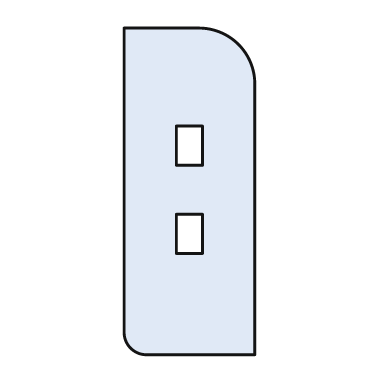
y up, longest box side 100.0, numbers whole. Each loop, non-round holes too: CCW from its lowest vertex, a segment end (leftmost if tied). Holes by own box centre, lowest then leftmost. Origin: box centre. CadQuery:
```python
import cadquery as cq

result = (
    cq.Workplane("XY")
    .moveTo(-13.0, -50.0)
    .lineTo(20.0, -50.0)
    .lineTo(20.0, 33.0)
    .threePointArc((15.0, 45.0), (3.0, 50.0))
    .lineTo(-20.0, 50.0)
    .lineTo(-20.0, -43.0)
    .threePointArc((-18.0, -48.0), (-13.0, -50.0))
    .close()
    .moveTo(-4.0, -19.0)
    .lineTo(4.0, -19.0)
    .lineTo(4.0, -7.0)
    .lineTo(-4.0, -7.0)
    .close()
    .moveTo(-4.0, 8.0)
    .lineTo(4.0, 8.0)
    .lineTo(4.0, 20.0)
    .lineTo(-4.0, 20.0)
    .close()
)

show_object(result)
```